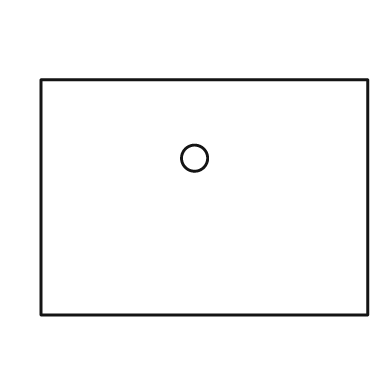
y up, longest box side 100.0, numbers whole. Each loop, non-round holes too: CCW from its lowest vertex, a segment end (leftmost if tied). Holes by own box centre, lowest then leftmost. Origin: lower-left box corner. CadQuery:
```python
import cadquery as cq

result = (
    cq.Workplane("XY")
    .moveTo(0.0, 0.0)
    .lineTo(100.0, 0.0)
    .lineTo(100.0, 72.0)
    .lineTo(0.0, 72.0)
    .close()
    .moveTo(47.0, 48.0)
    .circle(4.0)
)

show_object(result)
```